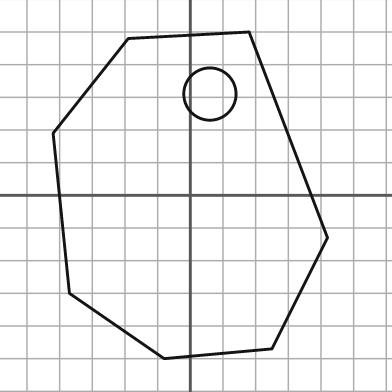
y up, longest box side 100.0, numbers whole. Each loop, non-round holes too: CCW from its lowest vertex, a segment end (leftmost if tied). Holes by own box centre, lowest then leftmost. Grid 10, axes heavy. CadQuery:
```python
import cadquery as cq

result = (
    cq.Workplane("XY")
    .moveTo(-8.0, -50.0)
    .lineTo(25.0, -47.0)
    .lineTo(42.0, -13.0)
    .lineTo(18.0, 50.0)
    .lineTo(-19.0, 48.0)
    .lineTo(-42.0, 19.0)
    .lineTo(-37.0, -30.0)
    .close()
    .moveTo(6.0, 31.0)
    .circle(8.0)
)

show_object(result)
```